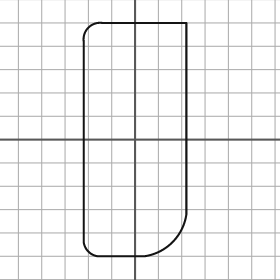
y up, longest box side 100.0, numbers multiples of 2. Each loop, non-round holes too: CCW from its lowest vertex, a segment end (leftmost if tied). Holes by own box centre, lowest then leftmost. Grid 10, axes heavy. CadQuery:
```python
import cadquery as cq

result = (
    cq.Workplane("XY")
    .moveTo(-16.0, -50.0)
    .lineTo(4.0, -50.0)
    .threePointArc((16.0, -44.0), (22.0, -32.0))
    .lineTo(22.0, 50.0)
    .lineTo(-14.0, 50.0)
    .threePointArc((-20.0, 48.0), (-22.0, 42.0))
    .lineTo(-22.0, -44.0)
    .threePointArc((-20.0, -48.0), (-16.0, -50.0))
    .close()
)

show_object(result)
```